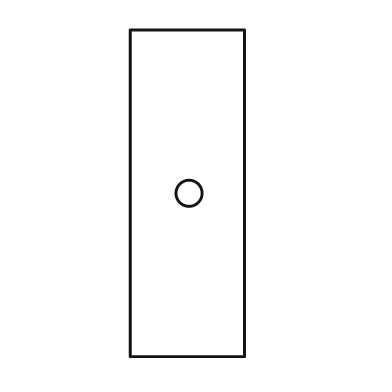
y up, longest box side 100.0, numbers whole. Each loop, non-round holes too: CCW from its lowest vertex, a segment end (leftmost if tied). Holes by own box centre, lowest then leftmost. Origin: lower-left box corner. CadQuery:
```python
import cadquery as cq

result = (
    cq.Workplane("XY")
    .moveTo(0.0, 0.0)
    .lineTo(35.0, 0.0)
    .lineTo(35.0, 100.0)
    .lineTo(0.0, 100.0)
    .close()
    .moveTo(18.0, 50.0)
    .circle(4.0)
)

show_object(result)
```